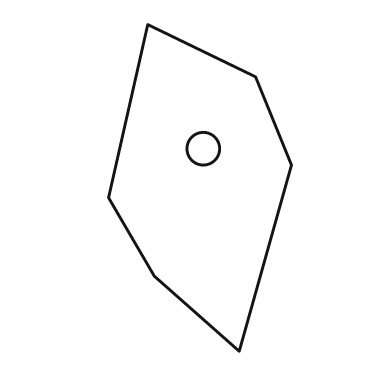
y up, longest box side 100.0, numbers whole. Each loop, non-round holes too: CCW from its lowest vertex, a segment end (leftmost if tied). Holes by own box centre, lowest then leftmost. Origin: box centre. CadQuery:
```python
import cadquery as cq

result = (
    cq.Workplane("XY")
    .moveTo(12.0, -50.0)
    .lineTo(28.0, 7.0)
    .lineTo(17.0, 34.0)
    .lineTo(-16.0, 50.0)
    .lineTo(-28.0, -3.0)
    .lineTo(-14.0, -27.0)
    .close()
    .moveTo(1.0, 12.0)
    .circle(5.0)
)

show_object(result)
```